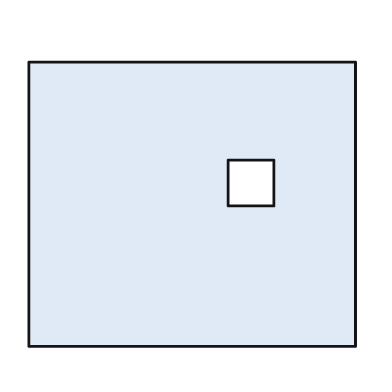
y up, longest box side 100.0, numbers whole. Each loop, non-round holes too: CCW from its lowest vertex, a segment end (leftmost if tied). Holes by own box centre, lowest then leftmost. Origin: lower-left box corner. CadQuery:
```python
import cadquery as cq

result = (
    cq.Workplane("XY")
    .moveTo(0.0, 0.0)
    .lineTo(100.0, 0.0)
    .lineTo(100.0, 87.0)
    .lineTo(0.0, 87.0)
    .close()
    .moveTo(61.0, 43.0)
    .lineTo(75.0, 43.0)
    .lineTo(75.0, 57.0)
    .lineTo(61.0, 57.0)
    .close()
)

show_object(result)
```